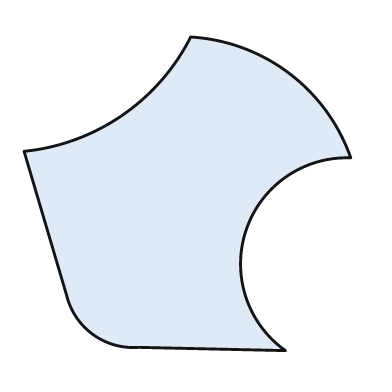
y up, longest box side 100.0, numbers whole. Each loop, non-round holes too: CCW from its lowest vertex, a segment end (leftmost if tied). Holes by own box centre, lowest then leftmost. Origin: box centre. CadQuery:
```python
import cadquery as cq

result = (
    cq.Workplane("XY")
    .moveTo(30.0, -48.0)
    .threePointArc((18.0, -11.0), (50.0, 11.0))
    .threePointArc((31.0, 37.0), (1.0, 48.0))
    .threePointArc((-20.0, 24.0), (-50.0, 13.0))
    .lineTo(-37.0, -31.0)
    .threePointArc((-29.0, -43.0), (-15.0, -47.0))
    .close()
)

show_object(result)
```